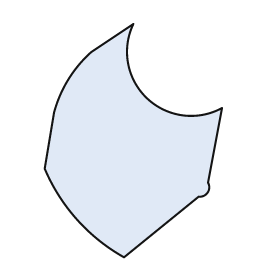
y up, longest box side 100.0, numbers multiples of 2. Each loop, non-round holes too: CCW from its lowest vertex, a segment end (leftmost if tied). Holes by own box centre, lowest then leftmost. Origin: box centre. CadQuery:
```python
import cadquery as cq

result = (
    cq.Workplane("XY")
    .moveTo(-4.0, -50.0)
    .lineTo(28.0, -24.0)
    .threePointArc((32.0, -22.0), (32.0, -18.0))
    .lineTo(38.0, 14.0)
    .threePointArc((6.0, 18.0), (0.0, 50.0))
    .lineTo(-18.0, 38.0)
    .threePointArc((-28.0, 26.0), (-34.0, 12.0))
    .lineTo(-38.0, -12.0)
    .threePointArc((-24.0, -34.0), (-4.0, -50.0))
    .close()
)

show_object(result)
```